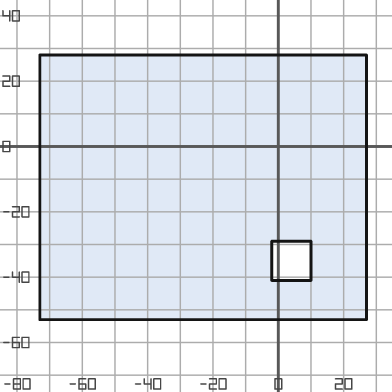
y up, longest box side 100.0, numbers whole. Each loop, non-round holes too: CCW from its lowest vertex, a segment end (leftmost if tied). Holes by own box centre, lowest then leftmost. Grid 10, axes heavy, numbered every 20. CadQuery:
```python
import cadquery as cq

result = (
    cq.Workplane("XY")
    .moveTo(-73.0, -53.0)
    .lineTo(27.0, -53.0)
    .lineTo(27.0, 28.0)
    .lineTo(-73.0, 28.0)
    .close()
    .moveTo(-2.0, -41.0)
    .lineTo(10.0, -41.0)
    .lineTo(10.0, -29.0)
    .lineTo(-2.0, -29.0)
    .close()
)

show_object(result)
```